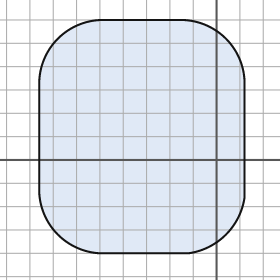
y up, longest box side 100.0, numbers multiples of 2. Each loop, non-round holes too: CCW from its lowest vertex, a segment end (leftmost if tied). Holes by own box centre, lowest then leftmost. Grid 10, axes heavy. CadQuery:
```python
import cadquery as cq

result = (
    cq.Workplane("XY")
    .moveTo(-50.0, -40.0)
    .lineTo(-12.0, -40.0)
    .threePointArc((4.0, -32.0), (12.0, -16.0))
    .lineTo(12.0, 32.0)
    .threePointArc((4.0, 52.0), (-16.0, 60.0))
    .lineTo(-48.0, 60.0)
    .threePointArc((-68.0, 52.0), (-76.0, 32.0))
    .lineTo(-76.0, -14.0)
    .threePointArc((-68.0, -32.0), (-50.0, -40.0))
    .close()
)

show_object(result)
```